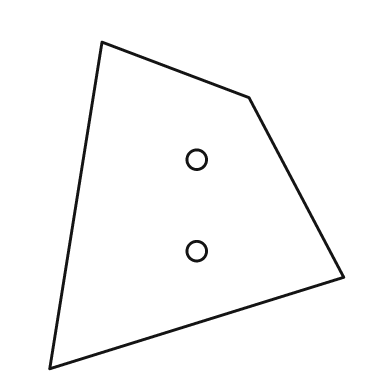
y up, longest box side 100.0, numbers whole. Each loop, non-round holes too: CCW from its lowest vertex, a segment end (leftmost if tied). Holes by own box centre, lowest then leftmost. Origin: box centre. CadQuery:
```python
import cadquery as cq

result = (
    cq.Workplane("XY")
    .moveTo(-45.0, -50.0)
    .lineTo(45.0, -22.0)
    .lineTo(16.0, 33.0)
    .lineTo(-29.0, 50.0)
    .close()
    .moveTo(0.0, -14.0)
    .circle(3.0)
    .moveTo(0.0, 14.0)
    .circle(3.0)
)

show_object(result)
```